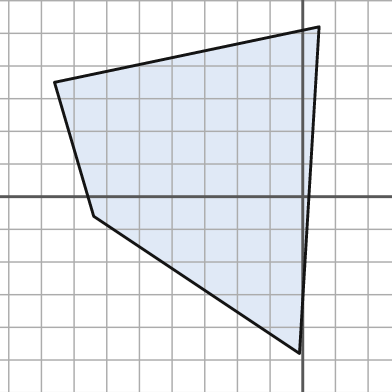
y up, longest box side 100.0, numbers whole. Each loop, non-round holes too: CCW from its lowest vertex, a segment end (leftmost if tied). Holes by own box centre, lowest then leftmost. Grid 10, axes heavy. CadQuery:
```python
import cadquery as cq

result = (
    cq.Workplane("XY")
    .moveTo(-1.0, -48.0)
    .lineTo(5.0, 52.0)
    .lineTo(-76.0, 35.0)
    .lineTo(-64.0, -6.0)
    .close()
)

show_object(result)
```